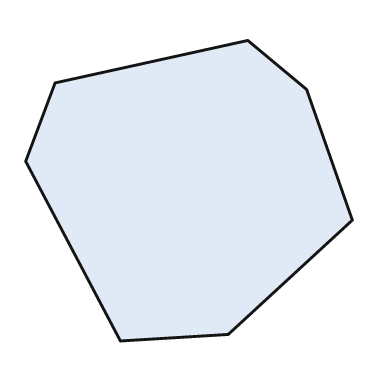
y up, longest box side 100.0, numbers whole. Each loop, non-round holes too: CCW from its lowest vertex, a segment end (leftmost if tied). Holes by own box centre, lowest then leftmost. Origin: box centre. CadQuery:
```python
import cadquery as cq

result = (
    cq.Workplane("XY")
    .moveTo(-21.0, -46.0)
    .lineTo(12.0, -44.0)
    .lineTo(50.0, -9.0)
    .lineTo(36.0, 31.0)
    .lineTo(18.0, 46.0)
    .lineTo(-41.0, 33.0)
    .lineTo(-50.0, 9.0)
    .close()
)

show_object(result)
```